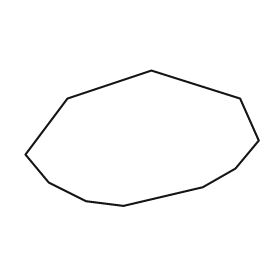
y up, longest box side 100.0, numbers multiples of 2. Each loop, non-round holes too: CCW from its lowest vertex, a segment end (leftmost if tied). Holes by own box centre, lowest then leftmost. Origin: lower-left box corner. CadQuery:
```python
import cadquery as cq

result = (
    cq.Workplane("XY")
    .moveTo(42.0, 0.0)
    .lineTo(76.0, 8.0)
    .lineTo(90.0, 16.0)
    .lineTo(100.0, 28.0)
    .lineTo(92.0, 46.0)
    .lineTo(54.0, 58.0)
    .lineTo(18.0, 46.0)
    .lineTo(0.0, 22.0)
    .lineTo(10.0, 10.0)
    .lineTo(26.0, 2.0)
    .close()
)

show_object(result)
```